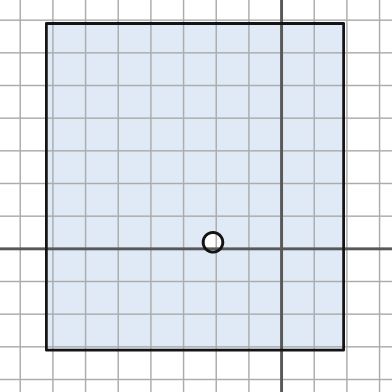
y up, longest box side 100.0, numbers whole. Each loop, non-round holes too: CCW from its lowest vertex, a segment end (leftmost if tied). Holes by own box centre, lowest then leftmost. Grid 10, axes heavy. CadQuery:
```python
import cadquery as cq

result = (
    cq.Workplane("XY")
    .moveTo(-72.0, -31.0)
    .lineTo(19.0, -31.0)
    .lineTo(19.0, 69.0)
    .lineTo(-72.0, 69.0)
    .close()
    .moveTo(-21.0, 2.0)
    .circle(3.0)
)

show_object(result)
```